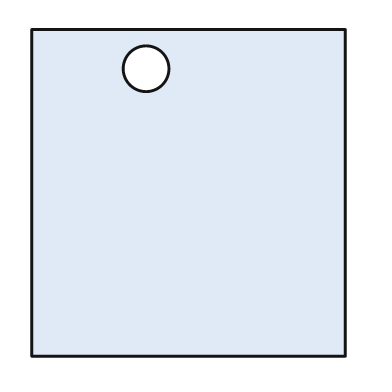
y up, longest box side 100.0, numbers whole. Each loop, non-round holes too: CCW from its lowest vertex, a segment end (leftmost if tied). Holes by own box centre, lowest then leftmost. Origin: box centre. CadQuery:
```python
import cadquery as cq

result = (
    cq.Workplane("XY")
    .moveTo(-48.0, -50.0)
    .lineTo(48.0, -50.0)
    .lineTo(48.0, 50.0)
    .lineTo(-48.0, 50.0)
    .close()
    .moveTo(-13.0, 38.0)
    .circle(7.0)
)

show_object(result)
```